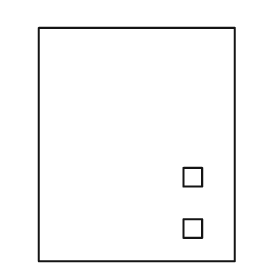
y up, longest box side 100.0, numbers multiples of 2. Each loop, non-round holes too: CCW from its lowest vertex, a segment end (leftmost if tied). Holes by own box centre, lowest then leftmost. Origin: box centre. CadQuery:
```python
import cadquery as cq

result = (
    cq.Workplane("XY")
    .moveTo(-42.0, -50.0)
    .lineTo(42.0, -50.0)
    .lineTo(42.0, 50.0)
    .lineTo(-42.0, 50.0)
    .close()
    .moveTo(20.0, -40.0)
    .lineTo(28.0, -40.0)
    .lineTo(28.0, -32.0)
    .lineTo(20.0, -32.0)
    .close()
    .moveTo(20.0, -18.0)
    .lineTo(28.0, -18.0)
    .lineTo(28.0, -10.0)
    .lineTo(20.0, -10.0)
    .close()
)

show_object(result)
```